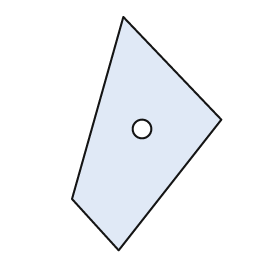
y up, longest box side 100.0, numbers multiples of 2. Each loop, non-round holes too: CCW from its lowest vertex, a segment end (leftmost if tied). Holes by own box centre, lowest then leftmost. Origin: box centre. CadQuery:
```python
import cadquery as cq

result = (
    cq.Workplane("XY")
    .moveTo(-12.0, -50.0)
    .lineTo(32.0, 6.0)
    .lineTo(-10.0, 50.0)
    .lineTo(-32.0, -28.0)
    .close()
    .moveTo(-2.0, 2.0)
    .circle(4.0)
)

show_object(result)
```